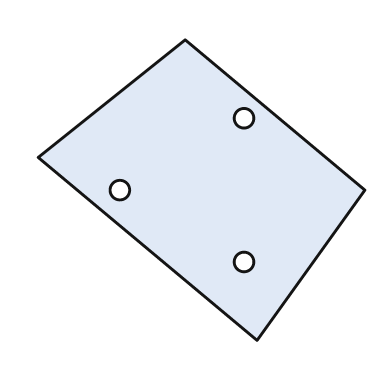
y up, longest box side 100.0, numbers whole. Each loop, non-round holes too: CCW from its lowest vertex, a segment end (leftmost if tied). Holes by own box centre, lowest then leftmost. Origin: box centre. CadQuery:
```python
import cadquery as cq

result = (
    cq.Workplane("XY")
    .moveTo(17.0, -46.0)
    .lineTo(50.0, 0.0)
    .lineTo(-5.0, 46.0)
    .lineTo(-50.0, 10.0)
    .close()
    .moveTo(13.0, -22.0)
    .circle(3.0)
    .moveTo(-25.0, 0.0)
    .circle(3.0)
    .moveTo(13.0, 22.0)
    .circle(3.0)
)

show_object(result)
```